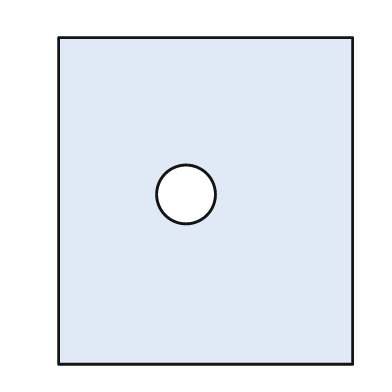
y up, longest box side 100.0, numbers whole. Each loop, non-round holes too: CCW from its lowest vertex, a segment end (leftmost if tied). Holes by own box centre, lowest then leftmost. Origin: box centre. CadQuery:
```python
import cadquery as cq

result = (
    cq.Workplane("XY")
    .moveTo(-45.0, -50.0)
    .lineTo(45.0, -50.0)
    .lineTo(45.0, 50.0)
    .lineTo(-45.0, 50.0)
    .close()
    .moveTo(-6.0, 2.0)
    .circle(9.0)
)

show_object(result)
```